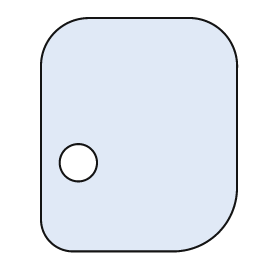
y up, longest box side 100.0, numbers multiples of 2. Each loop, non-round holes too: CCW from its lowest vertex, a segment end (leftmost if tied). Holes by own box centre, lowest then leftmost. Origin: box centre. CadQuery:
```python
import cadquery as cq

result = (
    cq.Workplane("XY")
    .moveTo(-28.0, -50.0)
    .lineTo(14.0, -50.0)
    .threePointArc((34.0, -42.0), (42.0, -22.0))
    .lineTo(42.0, 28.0)
    .threePointArc((36.0, 44.0), (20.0, 50.0))
    .lineTo(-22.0, 50.0)
    .threePointArc((-36.0, 44.0), (-42.0, 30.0))
    .lineTo(-42.0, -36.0)
    .threePointArc((-38.0, -46.0), (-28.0, -50.0))
    .close()
    .moveTo(-26.0, -12.0)
    .circle(8.0)
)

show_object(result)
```